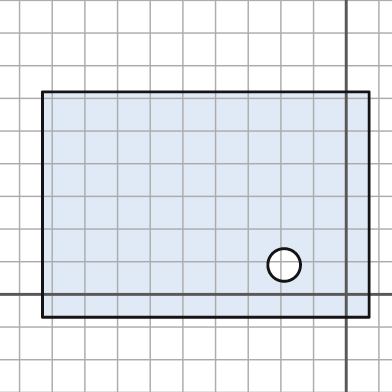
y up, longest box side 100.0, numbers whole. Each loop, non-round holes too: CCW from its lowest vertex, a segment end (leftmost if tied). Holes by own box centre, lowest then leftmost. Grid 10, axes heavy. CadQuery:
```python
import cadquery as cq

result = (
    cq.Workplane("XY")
    .moveTo(-93.0, -7.0)
    .lineTo(7.0, -7.0)
    .lineTo(7.0, 62.0)
    .lineTo(-93.0, 62.0)
    .close()
    .moveTo(-19.0, 9.0)
    .circle(5.0)
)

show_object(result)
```